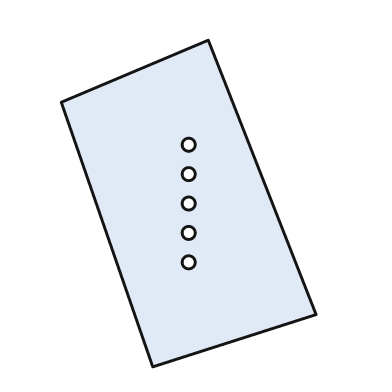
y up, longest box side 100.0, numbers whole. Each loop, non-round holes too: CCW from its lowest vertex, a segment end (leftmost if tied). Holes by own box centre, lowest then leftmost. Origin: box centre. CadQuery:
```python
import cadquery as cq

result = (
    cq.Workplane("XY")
    .moveTo(-11.0, -50.0)
    .lineTo(39.0, -34.0)
    .lineTo(6.0, 50.0)
    .lineTo(-39.0, 31.0)
    .close()
    .moveTo(0.0, -18.0)
    .circle(2.0)
    .moveTo(0.0, -9.0)
    .circle(2.0)
    .moveTo(0.0, 0.0)
    .circle(2.0)
    .moveTo(0.0, 9.0)
    .circle(2.0)
    .moveTo(0.0, 18.0)
    .circle(2.0)
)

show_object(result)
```